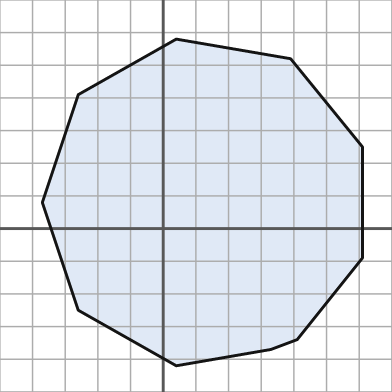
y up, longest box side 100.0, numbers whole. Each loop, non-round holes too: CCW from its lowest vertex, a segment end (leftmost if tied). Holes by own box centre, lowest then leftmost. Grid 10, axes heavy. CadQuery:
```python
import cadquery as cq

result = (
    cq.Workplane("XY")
    .moveTo(4.0, -42.0)
    .lineTo(33.0, -37.0)
    .lineTo(41.0, -34.0)
    .lineTo(61.0, -9.0)
    .lineTo(61.0, 25.0)
    .lineTo(39.0, 52.0)
    .lineTo(4.0, 58.0)
    .lineTo(-26.0, 41.0)
    .lineTo(-37.0, 8.0)
    .lineTo(-26.0, -25.0)
    .close()
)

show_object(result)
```